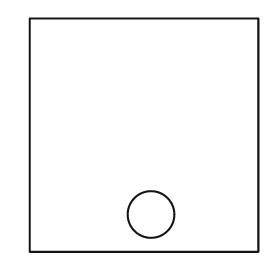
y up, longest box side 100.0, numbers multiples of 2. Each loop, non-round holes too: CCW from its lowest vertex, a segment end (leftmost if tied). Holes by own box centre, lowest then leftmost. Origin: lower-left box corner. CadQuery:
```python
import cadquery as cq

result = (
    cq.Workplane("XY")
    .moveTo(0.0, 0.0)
    .lineTo(98.0, 0.0)
    .lineTo(98.0, 100.0)
    .lineTo(0.0, 100.0)
    .close()
    .moveTo(52.0, 16.0)
    .circle(10.0)
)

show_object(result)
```